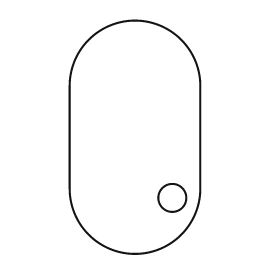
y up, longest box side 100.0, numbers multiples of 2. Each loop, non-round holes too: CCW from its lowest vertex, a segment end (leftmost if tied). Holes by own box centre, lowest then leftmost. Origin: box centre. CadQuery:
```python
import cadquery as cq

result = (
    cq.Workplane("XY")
    .moveTo(-28.0, -22.0)
    .threePointArc((0.0, -50.0), (28.0, -22.0))
    .lineTo(28.0, 22.0)
    .threePointArc((0.0, 50.0), (-28.0, 22.0))
    .close()
    .moveTo(16.0, -26.0)
    .circle(6.0)
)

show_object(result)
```